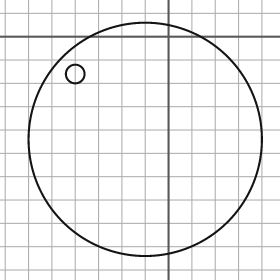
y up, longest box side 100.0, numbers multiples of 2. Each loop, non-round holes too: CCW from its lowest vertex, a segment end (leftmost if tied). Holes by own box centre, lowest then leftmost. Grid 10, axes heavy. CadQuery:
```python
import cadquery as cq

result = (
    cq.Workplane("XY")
    .moveTo(-10.0, -44.0)
    .circle(50.0)
    .moveTo(-40.0, -16.0)
    .circle(4.0)
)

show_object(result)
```